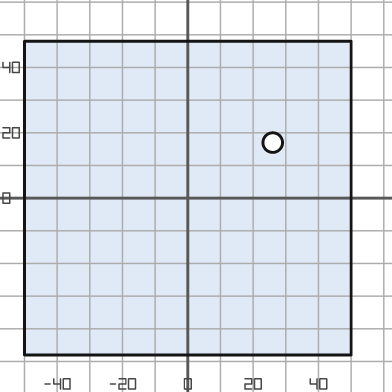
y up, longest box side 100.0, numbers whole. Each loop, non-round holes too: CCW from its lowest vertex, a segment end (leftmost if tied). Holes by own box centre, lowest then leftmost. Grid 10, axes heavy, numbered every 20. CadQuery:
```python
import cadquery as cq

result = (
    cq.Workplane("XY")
    .moveTo(-50.0, -48.0)
    .lineTo(50.0, -48.0)
    .lineTo(50.0, 48.0)
    .lineTo(-50.0, 48.0)
    .close()
    .moveTo(26.0, 17.0)
    .circle(3.0)
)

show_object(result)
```